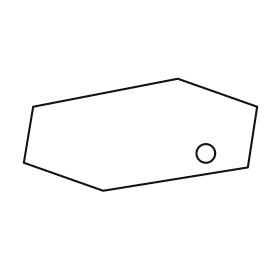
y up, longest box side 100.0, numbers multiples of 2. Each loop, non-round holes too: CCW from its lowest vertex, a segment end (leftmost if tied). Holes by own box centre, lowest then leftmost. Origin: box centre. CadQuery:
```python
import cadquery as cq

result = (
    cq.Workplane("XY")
    .moveTo(-16.0, -24.0)
    .lineTo(46.0, -14.0)
    .lineTo(50.0, 12.0)
    .lineTo(16.0, 24.0)
    .lineTo(-46.0, 12.0)
    .lineTo(-50.0, -12.0)
    .close()
    .moveTo(28.0, -8.0)
    .circle(4.0)
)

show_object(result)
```